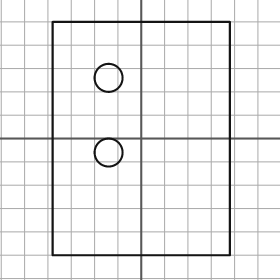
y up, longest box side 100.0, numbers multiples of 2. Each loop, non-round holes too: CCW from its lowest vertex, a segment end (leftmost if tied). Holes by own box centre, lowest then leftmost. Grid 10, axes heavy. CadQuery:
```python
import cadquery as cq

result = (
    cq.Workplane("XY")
    .moveTo(-38.0, -50.0)
    .lineTo(38.0, -50.0)
    .lineTo(38.0, 50.0)
    .lineTo(-38.0, 50.0)
    .close()
    .moveTo(-14.0, -6.0)
    .circle(6.0)
    .moveTo(-14.0, 26.0)
    .circle(6.0)
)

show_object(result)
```